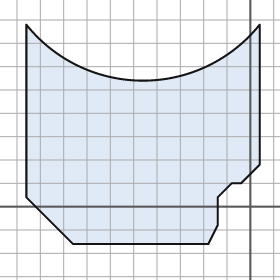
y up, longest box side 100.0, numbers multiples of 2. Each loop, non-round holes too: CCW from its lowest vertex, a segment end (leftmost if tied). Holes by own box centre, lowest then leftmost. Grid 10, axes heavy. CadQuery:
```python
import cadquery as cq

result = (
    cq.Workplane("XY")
    .moveTo(-76.0, -16.0)
    .lineTo(-18.0, -16.0)
    .lineTo(-14.0, -8.0)
    .lineTo(-14.0, 4.0)
    .lineTo(-8.0, 10.0)
    .lineTo(-4.0, 10.0)
    .lineTo(4.0, 18.0)
    .lineTo(4.0, 78.0)
    .threePointArc((-46.0, 54.0), (-96.0, 78.0))
    .lineTo(-96.0, 4.0)
    .close()
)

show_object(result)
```